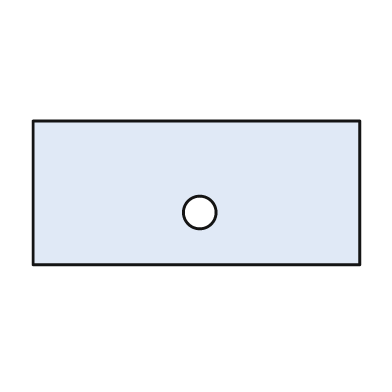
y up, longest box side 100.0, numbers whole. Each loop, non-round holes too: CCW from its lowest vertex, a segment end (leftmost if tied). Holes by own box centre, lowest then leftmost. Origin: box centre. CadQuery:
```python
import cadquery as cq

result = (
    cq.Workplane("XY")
    .moveTo(-50.0, -22.0)
    .lineTo(50.0, -22.0)
    .lineTo(50.0, 22.0)
    .lineTo(-50.0, 22.0)
    .close()
    .moveTo(1.0, -6.0)
    .circle(5.0)
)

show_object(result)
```